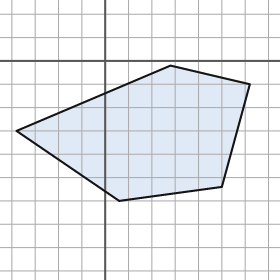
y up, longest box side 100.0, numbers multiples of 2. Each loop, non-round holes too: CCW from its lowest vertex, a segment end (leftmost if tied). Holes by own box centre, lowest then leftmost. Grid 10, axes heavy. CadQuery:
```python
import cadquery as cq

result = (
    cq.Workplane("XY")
    .moveTo(6.0, -60.0)
    .lineTo(50.0, -54.0)
    .lineTo(62.0, -10.0)
    .lineTo(28.0, -2.0)
    .lineTo(-38.0, -30.0)
    .close()
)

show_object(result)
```